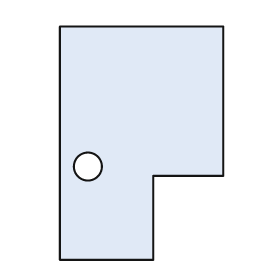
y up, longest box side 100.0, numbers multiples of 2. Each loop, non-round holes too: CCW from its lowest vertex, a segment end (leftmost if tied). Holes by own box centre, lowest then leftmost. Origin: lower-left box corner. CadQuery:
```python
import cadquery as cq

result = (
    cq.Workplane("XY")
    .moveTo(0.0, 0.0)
    .lineTo(40.0, 0.0)
    .lineTo(40.0, 36.0)
    .lineTo(70.0, 36.0)
    .lineTo(70.0, 100.0)
    .lineTo(0.0, 100.0)
    .close()
    .moveTo(12.0, 40.0)
    .circle(6.0)
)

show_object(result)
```